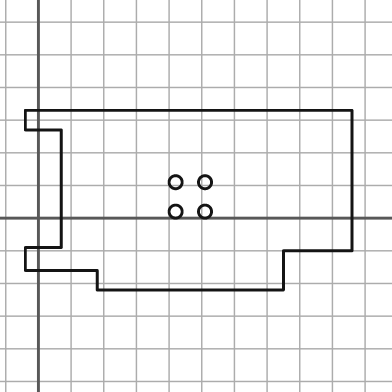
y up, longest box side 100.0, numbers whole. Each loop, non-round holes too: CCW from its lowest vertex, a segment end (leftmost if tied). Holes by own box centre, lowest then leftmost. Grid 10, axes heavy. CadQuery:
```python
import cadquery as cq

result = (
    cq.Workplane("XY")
    .moveTo(18.0, -22.0)
    .lineTo(75.0, -22.0)
    .lineTo(75.0, -10.0)
    .lineTo(96.0, -10.0)
    .lineTo(96.0, 33.0)
    .lineTo(-4.0, 33.0)
    .lineTo(-4.0, 27.0)
    .lineTo(7.0, 27.0)
    .lineTo(7.0, -9.0)
    .lineTo(-4.0, -9.0)
    .lineTo(-4.0, -16.0)
    .lineTo(18.0, -16.0)
    .close()
    .moveTo(42.0, 2.0)
    .circle(2.0)
    .moveTo(51.0, 2.0)
    .circle(2.0)
    .moveTo(42.0, 11.0)
    .circle(2.0)
    .moveTo(51.0, 11.0)
    .circle(2.0)
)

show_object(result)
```